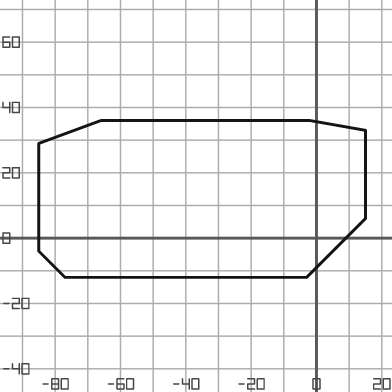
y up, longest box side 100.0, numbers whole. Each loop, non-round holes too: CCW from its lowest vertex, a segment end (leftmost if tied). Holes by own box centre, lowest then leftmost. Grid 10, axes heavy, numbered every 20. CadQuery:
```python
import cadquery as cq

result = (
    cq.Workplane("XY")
    .moveTo(-77.0, -12.0)
    .lineTo(-3.0, -12.0)
    .lineTo(15.0, 6.0)
    .lineTo(15.0, 33.0)
    .lineTo(-2.0, 36.0)
    .lineTo(-66.0, 36.0)
    .lineTo(-85.0, 29.0)
    .lineTo(-85.0, -4.0)
    .close()
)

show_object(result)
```